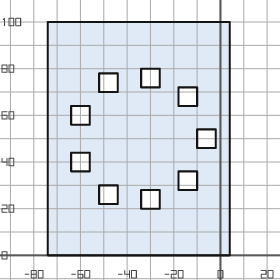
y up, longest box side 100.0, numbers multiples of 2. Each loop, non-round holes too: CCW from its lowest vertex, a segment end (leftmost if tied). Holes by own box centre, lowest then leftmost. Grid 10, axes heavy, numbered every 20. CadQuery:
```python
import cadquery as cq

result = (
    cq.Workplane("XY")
    .moveTo(-74.0, 0.0)
    .lineTo(4.0, 0.0)
    .lineTo(4.0, 100.0)
    .lineTo(-74.0, 100.0)
    .close()
    .moveTo(-34.0, 20.0)
    .lineTo(-26.0, 20.0)
    .lineTo(-26.0, 28.0)
    .lineTo(-34.0, 28.0)
    .close()
    .moveTo(-52.0, 22.0)
    .lineTo(-44.0, 22.0)
    .lineTo(-44.0, 30.0)
    .lineTo(-52.0, 30.0)
    .close()
    .moveTo(-18.0, 28.0)
    .lineTo(-10.0, 28.0)
    .lineTo(-10.0, 36.0)
    .lineTo(-18.0, 36.0)
    .close()
    .moveTo(-64.0, 36.0)
    .lineTo(-56.0, 36.0)
    .lineTo(-56.0, 44.0)
    .lineTo(-64.0, 44.0)
    .close()
    .moveTo(-10.0, 46.0)
    .lineTo(-2.0, 46.0)
    .lineTo(-2.0, 54.0)
    .lineTo(-10.0, 54.0)
    .close()
    .moveTo(-64.0, 56.0)
    .lineTo(-56.0, 56.0)
    .lineTo(-56.0, 64.0)
    .lineTo(-64.0, 64.0)
    .close()
    .moveTo(-18.0, 64.0)
    .lineTo(-10.0, 64.0)
    .lineTo(-10.0, 72.0)
    .lineTo(-18.0, 72.0)
    .close()
    .moveTo(-52.0, 70.0)
    .lineTo(-44.0, 70.0)
    .lineTo(-44.0, 78.0)
    .lineTo(-52.0, 78.0)
    .close()
    .moveTo(-34.0, 72.0)
    .lineTo(-26.0, 72.0)
    .lineTo(-26.0, 80.0)
    .lineTo(-34.0, 80.0)
    .close()
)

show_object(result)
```